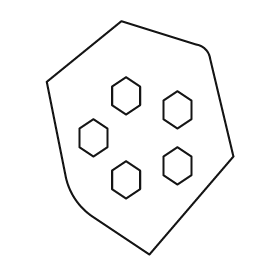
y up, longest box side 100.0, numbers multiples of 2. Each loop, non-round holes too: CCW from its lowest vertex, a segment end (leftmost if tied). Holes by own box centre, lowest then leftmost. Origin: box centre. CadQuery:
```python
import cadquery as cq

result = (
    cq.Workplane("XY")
    .moveTo(4.0, -50.0)
    .lineTo(40.0, -8.0)
    .lineTo(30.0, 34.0)
    .threePointArc((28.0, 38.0), (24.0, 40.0))
    .lineTo(-8.0, 50.0)
    .lineTo(-40.0, 24.0)
    .lineTo(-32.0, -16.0)
    .threePointArc((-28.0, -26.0), (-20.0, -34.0))
    .close()
    .moveTo(-6.0, -26.0)
    .lineTo(0.0, -22.0)
    .lineTo(0.0, -14.0)
    .lineTo(-6.0, -10.0)
    .lineTo(-12.0, -14.0)
    .lineTo(-12.0, -22.0)
    .close()
    .moveTo(16.0, -20.0)
    .lineTo(22.0, -16.0)
    .lineTo(22.0, -8.0)
    .lineTo(16.0, -4.0)
    .lineTo(10.0, -8.0)
    .lineTo(10.0, -16.0)
    .close()
    .moveTo(-20.0, -8.0)
    .lineTo(-14.0, -4.0)
    .lineTo(-14.0, 4.0)
    .lineTo(-20.0, 8.0)
    .lineTo(-26.0, 4.0)
    .lineTo(-26.0, -4.0)
    .close()
    .moveTo(16.0, 4.0)
    .lineTo(22.0, 8.0)
    .lineTo(22.0, 16.0)
    .lineTo(16.0, 20.0)
    .lineTo(10.0, 16.0)
    .lineTo(10.0, 8.0)
    .close()
    .moveTo(-6.0, 10.0)
    .lineTo(0.0, 14.0)
    .lineTo(0.0, 22.0)
    .lineTo(-6.0, 26.0)
    .lineTo(-12.0, 22.0)
    .lineTo(-12.0, 14.0)
    .close()
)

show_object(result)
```